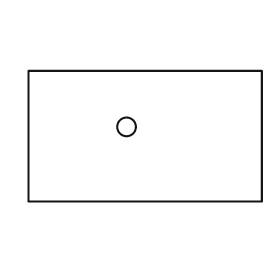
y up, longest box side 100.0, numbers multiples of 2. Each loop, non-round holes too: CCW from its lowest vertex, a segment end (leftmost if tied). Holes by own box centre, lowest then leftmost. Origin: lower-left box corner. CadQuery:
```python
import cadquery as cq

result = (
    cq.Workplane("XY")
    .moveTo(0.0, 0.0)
    .lineTo(100.0, 0.0)
    .lineTo(100.0, 56.0)
    .lineTo(0.0, 56.0)
    .close()
    .moveTo(42.0, 32.0)
    .circle(4.0)
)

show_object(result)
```